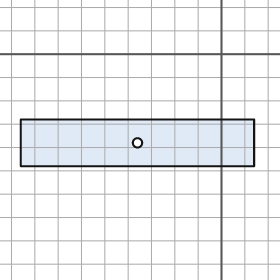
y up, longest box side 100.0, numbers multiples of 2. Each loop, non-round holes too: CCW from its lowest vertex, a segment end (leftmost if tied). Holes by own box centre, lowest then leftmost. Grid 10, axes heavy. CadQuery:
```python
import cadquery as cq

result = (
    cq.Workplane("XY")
    .moveTo(-86.0, -48.0)
    .lineTo(14.0, -48.0)
    .lineTo(14.0, -28.0)
    .lineTo(-86.0, -28.0)
    .close()
    .moveTo(-36.0, -38.0)
    .circle(2.0)
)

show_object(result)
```